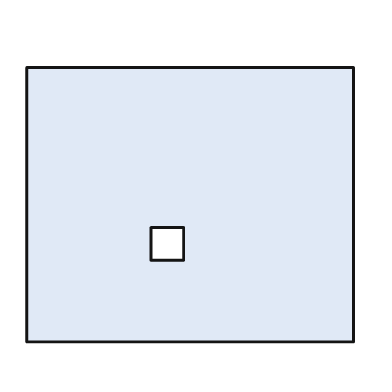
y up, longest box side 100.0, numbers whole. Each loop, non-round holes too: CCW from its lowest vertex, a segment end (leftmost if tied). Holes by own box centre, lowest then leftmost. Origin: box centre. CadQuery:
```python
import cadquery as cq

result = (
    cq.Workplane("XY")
    .moveTo(-50.0, -42.0)
    .lineTo(50.0, -42.0)
    .lineTo(50.0, 42.0)
    .lineTo(-50.0, 42.0)
    .close()
    .moveTo(-12.0, -17.0)
    .lineTo(-2.0, -17.0)
    .lineTo(-2.0, -7.0)
    .lineTo(-12.0, -7.0)
    .close()
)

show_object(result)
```